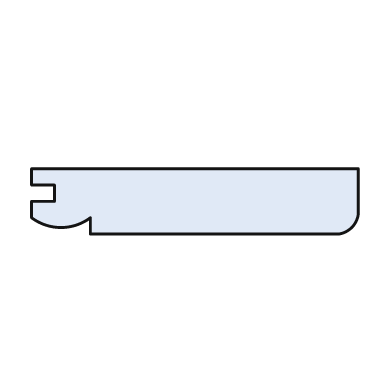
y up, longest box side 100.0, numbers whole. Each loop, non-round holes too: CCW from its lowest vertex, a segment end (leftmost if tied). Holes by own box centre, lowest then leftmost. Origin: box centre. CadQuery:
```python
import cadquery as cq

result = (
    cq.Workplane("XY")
    .moveTo(-32.0, -10.0)
    .lineTo(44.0, -10.0)
    .threePointArc((48.0, -8.0), (50.0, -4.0))
    .lineTo(50.0, 10.0)
    .lineTo(-50.0, 10.0)
    .lineTo(-50.0, 5.0)
    .lineTo(-43.0, 5.0)
    .lineTo(-43.0, 0.0)
    .lineTo(-50.0, 0.0)
    .lineTo(-50.0, -5.0)
    .threePointArc((-41.0, -8.0), (-32.0, -5.0))
    .close()
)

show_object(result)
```